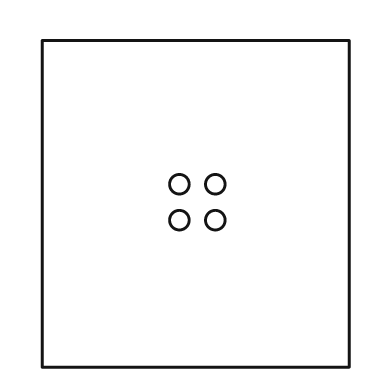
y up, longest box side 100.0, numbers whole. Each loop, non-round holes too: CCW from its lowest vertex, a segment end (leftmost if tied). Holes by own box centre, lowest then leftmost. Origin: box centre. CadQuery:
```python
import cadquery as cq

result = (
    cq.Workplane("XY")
    .moveTo(-47.0, -50.0)
    .lineTo(47.0, -50.0)
    .lineTo(47.0, 50.0)
    .lineTo(-47.0, 50.0)
    .close()
    .moveTo(-5.0, -5.0)
    .circle(3.0)
    .moveTo(6.0, -5.0)
    .circle(3.0)
    .moveTo(-5.0, 6.0)
    .circle(3.0)
    .moveTo(6.0, 6.0)
    .circle(3.0)
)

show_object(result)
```